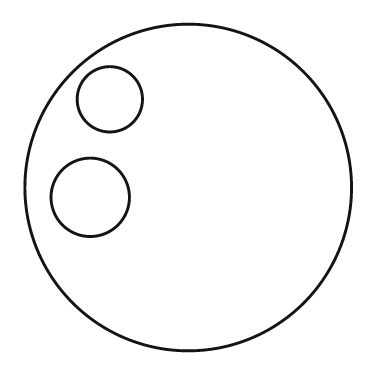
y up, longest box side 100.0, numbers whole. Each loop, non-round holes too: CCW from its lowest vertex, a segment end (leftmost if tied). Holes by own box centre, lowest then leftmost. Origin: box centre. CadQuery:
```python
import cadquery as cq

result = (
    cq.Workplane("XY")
    .moveTo(0.0, 0.0)
    .circle(50.0)
    .moveTo(-30.0, -3.0)
    .circle(12.0)
    .moveTo(-24.0, 27.0)
    .circle(10.0)
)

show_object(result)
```